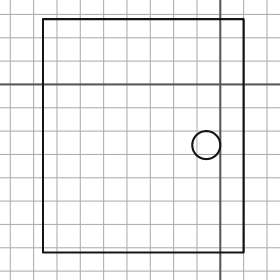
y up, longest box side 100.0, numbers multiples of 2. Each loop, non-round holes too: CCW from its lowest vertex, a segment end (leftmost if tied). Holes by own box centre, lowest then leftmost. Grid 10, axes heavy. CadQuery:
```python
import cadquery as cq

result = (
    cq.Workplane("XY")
    .moveTo(-76.0, -72.0)
    .lineTo(10.0, -72.0)
    .lineTo(10.0, 28.0)
    .lineTo(-76.0, 28.0)
    .close()
    .moveTo(-6.0, -26.0)
    .circle(6.0)
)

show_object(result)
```